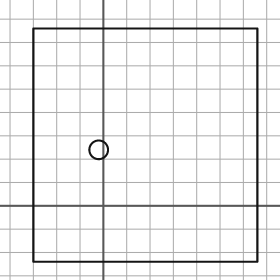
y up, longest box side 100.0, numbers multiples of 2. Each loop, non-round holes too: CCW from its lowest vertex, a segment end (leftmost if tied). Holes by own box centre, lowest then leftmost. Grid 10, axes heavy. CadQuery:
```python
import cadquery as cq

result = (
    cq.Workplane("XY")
    .moveTo(-30.0, -24.0)
    .lineTo(66.0, -24.0)
    .lineTo(66.0, 76.0)
    .lineTo(-30.0, 76.0)
    .close()
    .moveTo(-2.0, 24.0)
    .circle(4.0)
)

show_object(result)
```